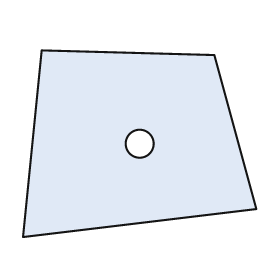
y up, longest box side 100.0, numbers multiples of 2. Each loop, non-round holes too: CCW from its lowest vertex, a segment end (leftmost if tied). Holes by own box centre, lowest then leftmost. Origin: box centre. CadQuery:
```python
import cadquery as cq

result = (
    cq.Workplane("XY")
    .moveTo(-50.0, -40.0)
    .lineTo(50.0, -28.0)
    .lineTo(32.0, 38.0)
    .lineTo(-42.0, 40.0)
    .close()
    .moveTo(0.0, 0.0)
    .circle(6.0)
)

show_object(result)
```